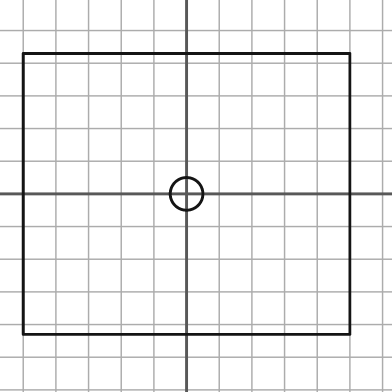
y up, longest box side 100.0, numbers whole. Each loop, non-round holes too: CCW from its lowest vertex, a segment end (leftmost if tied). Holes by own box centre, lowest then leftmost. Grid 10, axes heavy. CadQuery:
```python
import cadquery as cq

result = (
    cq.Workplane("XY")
    .moveTo(-50.0, -43.0)
    .lineTo(50.0, -43.0)
    .lineTo(50.0, 43.0)
    .lineTo(-50.0, 43.0)
    .close()
    .moveTo(0.0, 0.0)
    .circle(5.0)
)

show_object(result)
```